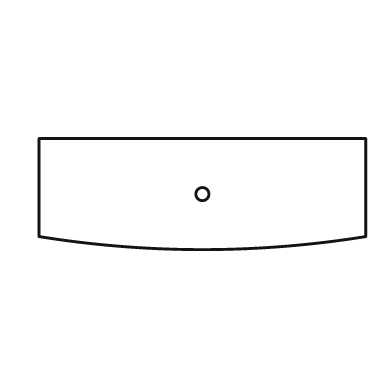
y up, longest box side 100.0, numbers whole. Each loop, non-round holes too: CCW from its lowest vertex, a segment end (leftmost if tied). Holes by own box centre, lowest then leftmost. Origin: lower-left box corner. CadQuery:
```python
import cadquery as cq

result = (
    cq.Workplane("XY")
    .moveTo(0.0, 4.0)
    .threePointArc((50.0, 0.0), (100.0, 4.0))
    .lineTo(100.0, 34.0)
    .lineTo(0.0, 34.0)
    .close()
    .moveTo(50.0, 17.0)
    .circle(2.0)
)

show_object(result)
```